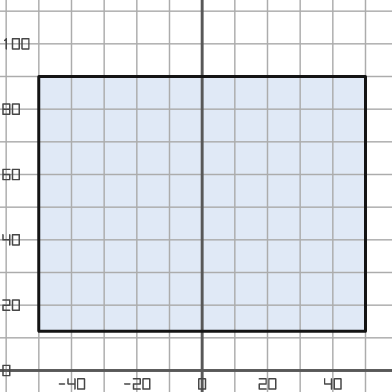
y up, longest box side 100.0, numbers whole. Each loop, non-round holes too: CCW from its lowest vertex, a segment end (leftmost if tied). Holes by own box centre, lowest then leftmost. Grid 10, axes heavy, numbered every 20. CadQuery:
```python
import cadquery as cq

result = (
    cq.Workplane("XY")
    .moveTo(-50.0, 12.0)
    .lineTo(50.0, 12.0)
    .lineTo(50.0, 90.0)
    .lineTo(-50.0, 90.0)
    .close()
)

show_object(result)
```